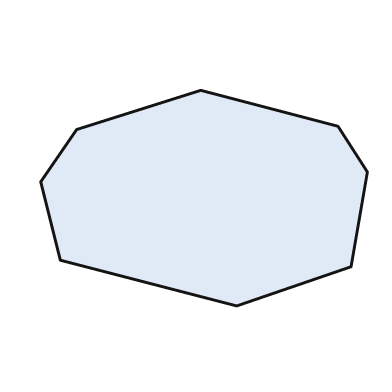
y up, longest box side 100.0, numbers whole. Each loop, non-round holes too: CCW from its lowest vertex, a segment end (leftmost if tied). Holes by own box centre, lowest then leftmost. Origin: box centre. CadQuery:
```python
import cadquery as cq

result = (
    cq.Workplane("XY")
    .moveTo(10.0, -33.0)
    .lineTo(45.0, -21.0)
    .lineTo(50.0, 8.0)
    .lineTo(41.0, 22.0)
    .lineTo(-1.0, 33.0)
    .lineTo(-39.0, 21.0)
    .lineTo(-50.0, 5.0)
    .lineTo(-44.0, -19.0)
    .close()
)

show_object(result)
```